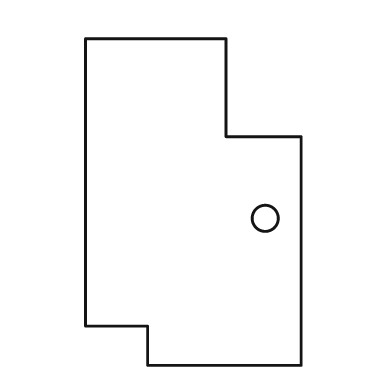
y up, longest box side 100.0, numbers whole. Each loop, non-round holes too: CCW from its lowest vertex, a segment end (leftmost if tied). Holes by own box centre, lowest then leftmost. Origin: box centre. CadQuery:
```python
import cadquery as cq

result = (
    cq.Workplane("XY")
    .moveTo(-14.0, -50.0)
    .lineTo(33.0, -50.0)
    .lineTo(33.0, 20.0)
    .lineTo(10.0, 20.0)
    .lineTo(10.0, 50.0)
    .lineTo(-33.0, 50.0)
    .lineTo(-33.0, -38.0)
    .lineTo(-14.0, -38.0)
    .close()
    .moveTo(22.0, -5.0)
    .circle(4.0)
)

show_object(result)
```